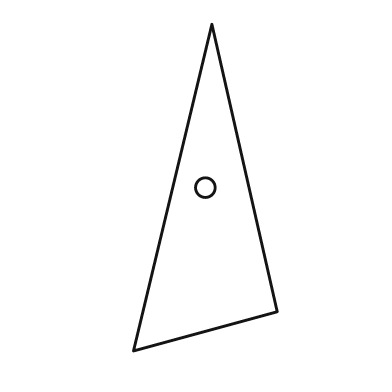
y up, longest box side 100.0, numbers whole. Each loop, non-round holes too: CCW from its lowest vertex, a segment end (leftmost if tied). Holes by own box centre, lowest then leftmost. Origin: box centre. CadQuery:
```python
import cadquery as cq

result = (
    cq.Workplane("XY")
    .moveTo(-22.0, -50.0)
    .lineTo(22.0, -38.0)
    .lineTo(2.0, 50.0)
    .close()
    .moveTo(0.0, 0.0)
    .circle(3.0)
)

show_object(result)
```